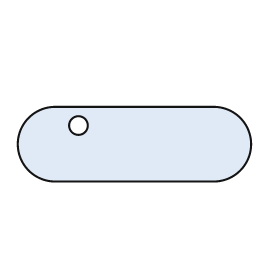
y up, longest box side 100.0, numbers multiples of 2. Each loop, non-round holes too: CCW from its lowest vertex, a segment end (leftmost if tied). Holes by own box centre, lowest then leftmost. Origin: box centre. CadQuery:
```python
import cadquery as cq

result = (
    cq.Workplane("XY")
    .moveTo(-34.0, -16.0)
    .lineTo(34.0, -16.0)
    .threePointArc((50.0, 0.0), (34.0, 16.0))
    .lineTo(-34.0, 16.0)
    .threePointArc((-50.0, 0.0), (-34.0, -16.0))
    .close()
    .moveTo(-24.0, 8.0)
    .circle(4.0)
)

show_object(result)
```